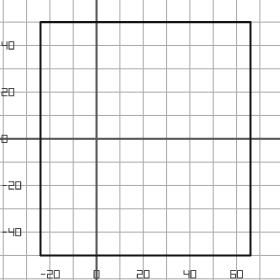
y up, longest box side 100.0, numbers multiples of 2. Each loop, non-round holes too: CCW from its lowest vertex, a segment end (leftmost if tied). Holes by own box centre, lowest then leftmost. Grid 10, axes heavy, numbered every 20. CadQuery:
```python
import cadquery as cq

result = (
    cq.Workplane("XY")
    .moveTo(-24.0, -50.0)
    .lineTo(66.0, -50.0)
    .lineTo(66.0, 50.0)
    .lineTo(-24.0, 50.0)
    .close()
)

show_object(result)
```